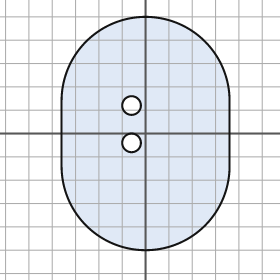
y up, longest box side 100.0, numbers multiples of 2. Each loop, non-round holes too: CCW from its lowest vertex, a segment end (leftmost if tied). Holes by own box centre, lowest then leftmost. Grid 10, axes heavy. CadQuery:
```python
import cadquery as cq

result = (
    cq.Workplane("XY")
    .moveTo(-36.0, -14.0)
    .threePointArc((0.0, -50.0), (36.0, -14.0))
    .lineTo(36.0, 14.0)
    .threePointArc((0.0, 50.0), (-36.0, 14.0))
    .close()
    .moveTo(-6.0, -4.0)
    .circle(4.0)
    .moveTo(-6.0, 12.0)
    .circle(4.0)
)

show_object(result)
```